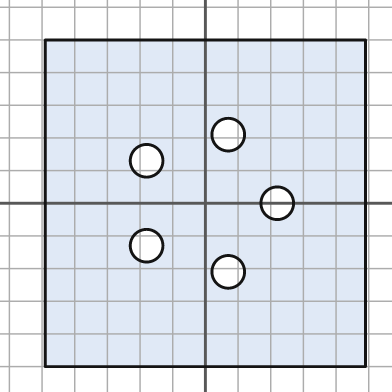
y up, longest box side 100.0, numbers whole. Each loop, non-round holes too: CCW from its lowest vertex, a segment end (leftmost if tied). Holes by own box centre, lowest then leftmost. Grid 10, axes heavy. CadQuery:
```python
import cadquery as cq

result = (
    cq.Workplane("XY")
    .moveTo(-49.0, -50.0)
    .lineTo(49.0, -50.0)
    .lineTo(49.0, 50.0)
    .lineTo(-49.0, 50.0)
    .close()
    .moveTo(7.0, -21.0)
    .circle(5.0)
    .moveTo(-18.0, -13.0)
    .circle(5.0)
    .moveTo(22.0, 0.0)
    .circle(5.0)
    .moveTo(-18.0, 13.0)
    .circle(5.0)
    .moveTo(7.0, 21.0)
    .circle(5.0)
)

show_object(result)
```